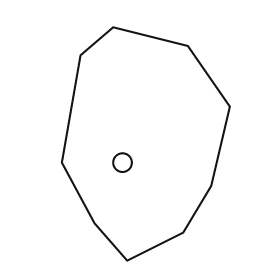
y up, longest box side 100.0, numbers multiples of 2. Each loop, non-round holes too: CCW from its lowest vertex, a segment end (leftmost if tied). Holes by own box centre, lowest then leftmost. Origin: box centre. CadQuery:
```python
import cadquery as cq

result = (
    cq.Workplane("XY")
    .moveTo(-8.0, -50.0)
    .lineTo(16.0, -38.0)
    .lineTo(28.0, -18.0)
    .lineTo(36.0, 16.0)
    .lineTo(18.0, 42.0)
    .lineTo(-14.0, 50.0)
    .lineTo(-28.0, 38.0)
    .lineTo(-36.0, -8.0)
    .lineTo(-22.0, -34.0)
    .close()
    .moveTo(-10.0, -8.0)
    .circle(4.0)
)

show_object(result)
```